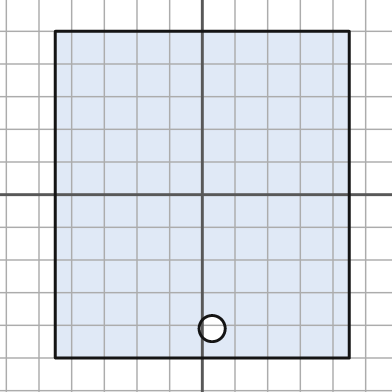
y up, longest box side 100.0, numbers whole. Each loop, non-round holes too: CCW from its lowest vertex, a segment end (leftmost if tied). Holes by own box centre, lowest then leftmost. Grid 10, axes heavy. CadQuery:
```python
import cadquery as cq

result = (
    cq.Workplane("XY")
    .moveTo(-45.0, -50.0)
    .lineTo(45.0, -50.0)
    .lineTo(45.0, 50.0)
    .lineTo(-45.0, 50.0)
    .close()
    .moveTo(3.0, -41.0)
    .circle(4.0)
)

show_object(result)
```